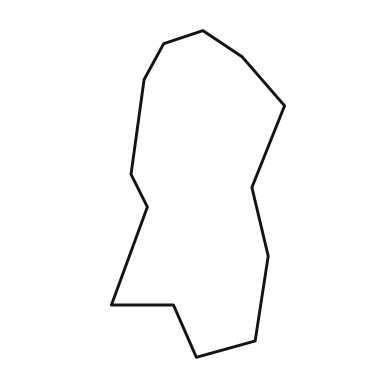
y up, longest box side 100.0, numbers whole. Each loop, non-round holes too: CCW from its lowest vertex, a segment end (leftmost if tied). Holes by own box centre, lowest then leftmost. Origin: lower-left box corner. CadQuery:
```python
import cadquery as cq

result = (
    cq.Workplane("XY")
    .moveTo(26.0, 0.0)
    .lineTo(44.0, 5.0)
    .lineTo(48.0, 31.0)
    .lineTo(43.0, 52.0)
    .lineTo(53.0, 77.0)
    .lineTo(40.0, 92.0)
    .lineTo(28.0, 100.0)
    .lineTo(16.0, 96.0)
    .lineTo(10.0, 85.0)
    .lineTo(6.0, 56.0)
    .lineTo(11.0, 46.0)
    .lineTo(0.0, 16.0)
    .lineTo(19.0, 16.0)
    .close()
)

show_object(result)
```